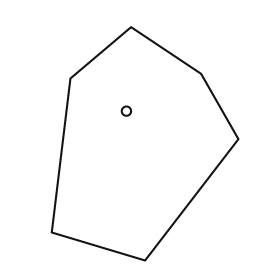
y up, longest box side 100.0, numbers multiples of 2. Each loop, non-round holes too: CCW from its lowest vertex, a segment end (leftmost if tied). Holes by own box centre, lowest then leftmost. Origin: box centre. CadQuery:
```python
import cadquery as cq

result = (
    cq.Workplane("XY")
    .moveTo(0.0, -50.0)
    .lineTo(40.0, 2.0)
    .lineTo(24.0, 30.0)
    .lineTo(-6.0, 50.0)
    .lineTo(-32.0, 28.0)
    .lineTo(-40.0, -38.0)
    .close()
    .moveTo(-8.0, 14.0)
    .circle(2.0)
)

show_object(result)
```